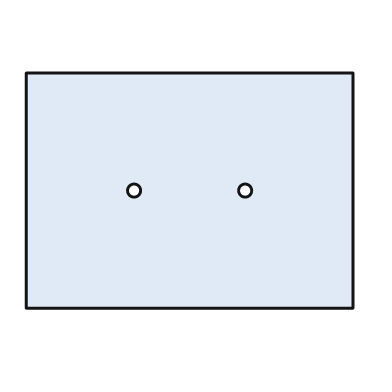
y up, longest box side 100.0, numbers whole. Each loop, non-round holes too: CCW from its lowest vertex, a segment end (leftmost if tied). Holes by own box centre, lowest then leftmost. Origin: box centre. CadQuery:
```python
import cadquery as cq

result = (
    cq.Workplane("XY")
    .moveTo(-50.0, -36.0)
    .lineTo(50.0, -36.0)
    .lineTo(50.0, 36.0)
    .lineTo(-50.0, 36.0)
    .close()
    .moveTo(-17.0, 0.0)
    .circle(2.0)
    .moveTo(17.0, 0.0)
    .circle(2.0)
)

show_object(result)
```